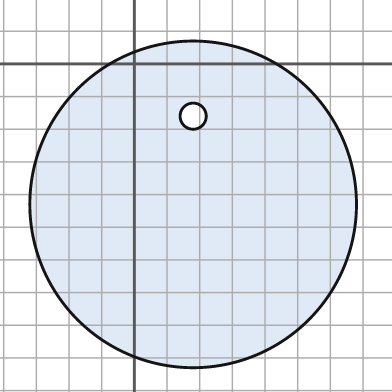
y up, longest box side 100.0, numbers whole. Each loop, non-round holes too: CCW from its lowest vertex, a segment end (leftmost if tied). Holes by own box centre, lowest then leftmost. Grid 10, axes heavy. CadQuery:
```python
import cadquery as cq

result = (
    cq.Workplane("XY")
    .moveTo(18.0, -43.0)
    .circle(50.0)
    .moveTo(18.0, -16.0)
    .circle(4.0)
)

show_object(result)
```